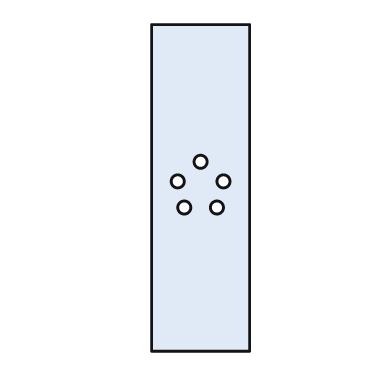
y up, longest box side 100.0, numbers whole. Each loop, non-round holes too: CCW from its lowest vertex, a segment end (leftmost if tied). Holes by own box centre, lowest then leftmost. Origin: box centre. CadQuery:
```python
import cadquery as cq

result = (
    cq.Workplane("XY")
    .moveTo(-15.0, -50.0)
    .lineTo(15.0, -50.0)
    .lineTo(15.0, 50.0)
    .lineTo(-15.0, 50.0)
    .close()
    .moveTo(-5.0, -6.0)
    .circle(2.0)
    .moveTo(5.0, -6.0)
    .circle(2.0)
    .moveTo(-7.0, 2.0)
    .circle(2.0)
    .moveTo(7.0, 2.0)
    .circle(2.0)
    .moveTo(0.0, 8.0)
    .circle(2.0)
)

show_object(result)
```